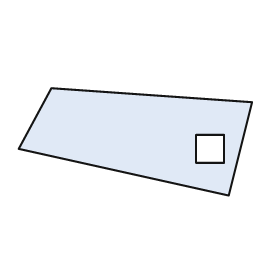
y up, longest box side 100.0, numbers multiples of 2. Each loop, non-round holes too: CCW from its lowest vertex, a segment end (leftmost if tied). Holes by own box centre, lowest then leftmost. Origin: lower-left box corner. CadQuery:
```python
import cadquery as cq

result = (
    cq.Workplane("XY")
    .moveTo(90.0, 0.0)
    .lineTo(100.0, 40.0)
    .lineTo(14.0, 46.0)
    .lineTo(0.0, 20.0)
    .close()
    .moveTo(76.0, 14.0)
    .lineTo(88.0, 14.0)
    .lineTo(88.0, 26.0)
    .lineTo(76.0, 26.0)
    .close()
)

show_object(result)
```